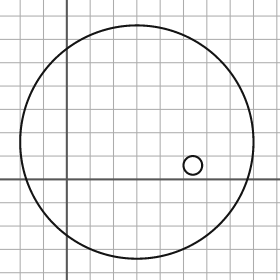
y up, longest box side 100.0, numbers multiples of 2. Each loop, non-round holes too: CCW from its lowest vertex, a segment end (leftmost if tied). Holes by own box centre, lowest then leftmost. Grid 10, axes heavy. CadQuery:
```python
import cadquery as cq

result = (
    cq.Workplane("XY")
    .moveTo(30.0, 16.0)
    .circle(50.0)
    .moveTo(54.0, 6.0)
    .circle(4.0)
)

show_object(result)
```